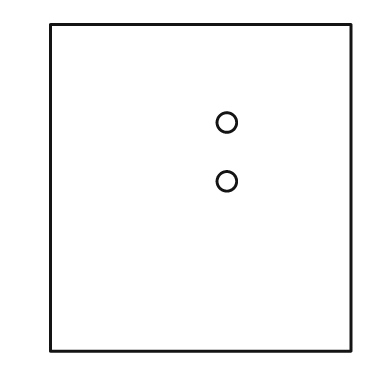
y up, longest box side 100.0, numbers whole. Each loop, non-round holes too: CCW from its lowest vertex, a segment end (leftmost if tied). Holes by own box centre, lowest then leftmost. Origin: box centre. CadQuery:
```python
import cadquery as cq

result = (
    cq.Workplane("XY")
    .moveTo(-46.0, -50.0)
    .lineTo(46.0, -50.0)
    .lineTo(46.0, 50.0)
    .lineTo(-46.0, 50.0)
    .close()
    .moveTo(8.0, 2.0)
    .circle(3.0)
    .moveTo(8.0, 20.0)
    .circle(3.0)
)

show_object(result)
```